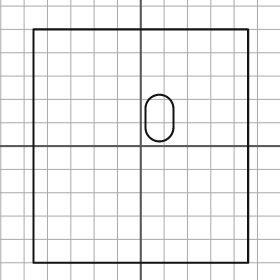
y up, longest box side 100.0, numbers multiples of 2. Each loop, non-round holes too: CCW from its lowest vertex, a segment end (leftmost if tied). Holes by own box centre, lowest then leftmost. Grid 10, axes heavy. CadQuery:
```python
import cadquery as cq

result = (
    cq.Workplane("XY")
    .moveTo(-46.0, -50.0)
    .lineTo(46.0, -50.0)
    .lineTo(46.0, 50.0)
    .lineTo(-46.0, 50.0)
    .close()
    .moveTo(2.0, 8.0)
    .threePointArc((8.0, 2.0), (14.0, 8.0))
    .lineTo(14.0, 16.0)
    .threePointArc((8.0, 22.0), (2.0, 16.0))
    .close()
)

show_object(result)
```